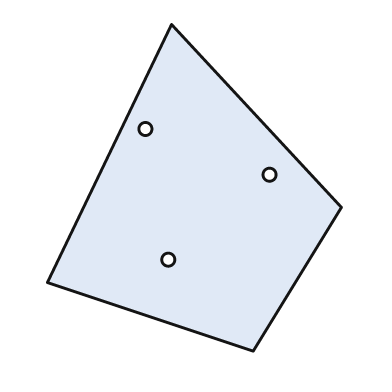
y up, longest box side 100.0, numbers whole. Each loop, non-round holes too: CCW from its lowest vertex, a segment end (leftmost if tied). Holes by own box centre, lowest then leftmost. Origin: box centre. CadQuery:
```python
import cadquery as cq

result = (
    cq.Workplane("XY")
    .moveTo(18.0, -50.0)
    .lineTo(45.0, -6.0)
    .lineTo(-7.0, 50.0)
    .lineTo(-45.0, -29.0)
    .close()
    .moveTo(-8.0, -22.0)
    .circle(2.0)
    .moveTo(23.0, 4.0)
    .circle(2.0)
    .moveTo(-15.0, 18.0)
    .circle(2.0)
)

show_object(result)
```